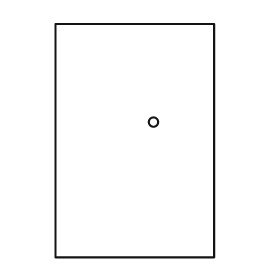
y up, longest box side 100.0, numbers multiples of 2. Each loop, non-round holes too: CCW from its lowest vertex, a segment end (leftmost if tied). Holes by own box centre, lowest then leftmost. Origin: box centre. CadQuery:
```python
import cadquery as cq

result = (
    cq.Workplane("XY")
    .moveTo(-34.0, -50.0)
    .lineTo(34.0, -50.0)
    .lineTo(34.0, 50.0)
    .lineTo(-34.0, 50.0)
    .close()
    .moveTo(8.0, 8.0)
    .circle(2.0)
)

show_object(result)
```